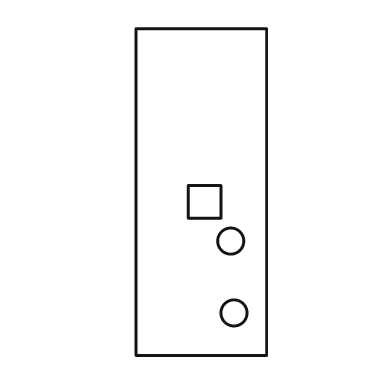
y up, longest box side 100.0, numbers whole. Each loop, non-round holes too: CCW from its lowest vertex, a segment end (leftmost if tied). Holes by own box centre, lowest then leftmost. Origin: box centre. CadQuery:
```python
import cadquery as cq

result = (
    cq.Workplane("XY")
    .moveTo(-20.0, -50.0)
    .lineTo(20.0, -50.0)
    .lineTo(20.0, 50.0)
    .lineTo(-20.0, 50.0)
    .close()
    .moveTo(10.0, -37.0)
    .circle(4.0)
    .moveTo(9.0, -15.0)
    .circle(4.0)
    .moveTo(-4.0, -8.0)
    .lineTo(6.0, -8.0)
    .lineTo(6.0, 2.0)
    .lineTo(-4.0, 2.0)
    .close()
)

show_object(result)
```